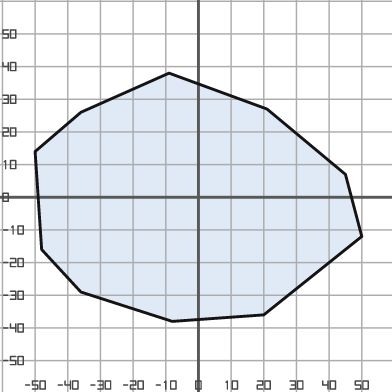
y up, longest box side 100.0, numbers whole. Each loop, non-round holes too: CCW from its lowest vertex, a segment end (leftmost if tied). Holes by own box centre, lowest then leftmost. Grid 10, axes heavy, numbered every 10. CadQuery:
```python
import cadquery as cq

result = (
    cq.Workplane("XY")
    .moveTo(-8.0, -38.0)
    .lineTo(20.0, -36.0)
    .lineTo(50.0, -12.0)
    .lineTo(45.0, 7.0)
    .lineTo(21.0, 27.0)
    .lineTo(-9.0, 38.0)
    .lineTo(-36.0, 26.0)
    .lineTo(-50.0, 14.0)
    .lineTo(-48.0, -16.0)
    .lineTo(-36.0, -29.0)
    .close()
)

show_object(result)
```